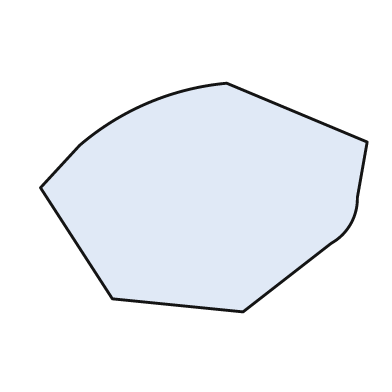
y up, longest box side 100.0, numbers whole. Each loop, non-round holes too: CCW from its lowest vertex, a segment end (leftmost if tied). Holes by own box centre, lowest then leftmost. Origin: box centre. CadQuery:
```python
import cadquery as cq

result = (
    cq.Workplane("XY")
    .moveTo(12.0, -35.0)
    .lineTo(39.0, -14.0)
    .threePointArc((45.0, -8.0), (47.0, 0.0))
    .lineTo(50.0, 17.0)
    .lineTo(7.0, 35.0)
    .threePointArc((-17.0, 29.0), (-38.0, 16.0))
    .lineTo(-50.0, 3.0)
    .lineTo(-28.0, -31.0)
    .close()
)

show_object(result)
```